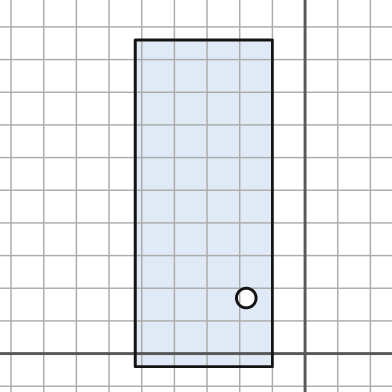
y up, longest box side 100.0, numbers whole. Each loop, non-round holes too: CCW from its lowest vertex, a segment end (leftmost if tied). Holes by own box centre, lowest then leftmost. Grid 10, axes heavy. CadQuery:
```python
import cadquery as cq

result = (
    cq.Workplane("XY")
    .moveTo(-52.0, -4.0)
    .lineTo(-10.0, -4.0)
    .lineTo(-10.0, 96.0)
    .lineTo(-52.0, 96.0)
    .close()
    .moveTo(-18.0, 17.0)
    .circle(3.0)
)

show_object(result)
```